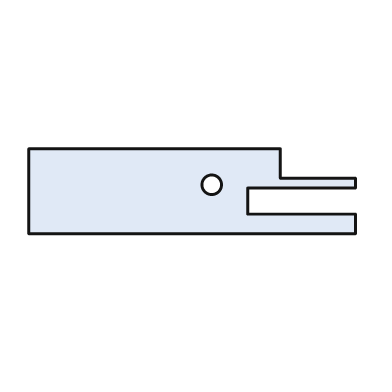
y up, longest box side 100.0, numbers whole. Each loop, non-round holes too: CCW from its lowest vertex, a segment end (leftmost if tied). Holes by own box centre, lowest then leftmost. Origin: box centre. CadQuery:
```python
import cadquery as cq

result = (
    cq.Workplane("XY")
    .moveTo(-50.0, -13.0)
    .lineTo(50.0, -13.0)
    .lineTo(50.0, -7.0)
    .lineTo(17.0, -7.0)
    .lineTo(17.0, 1.0)
    .lineTo(50.0, 1.0)
    .lineTo(50.0, 4.0)
    .lineTo(27.0, 4.0)
    .lineTo(27.0, 13.0)
    .lineTo(-50.0, 13.0)
    .close()
    .moveTo(6.0, 2.0)
    .circle(3.0)
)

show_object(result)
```